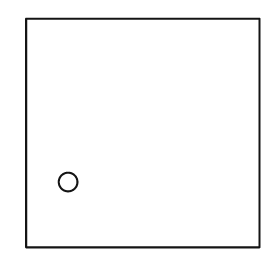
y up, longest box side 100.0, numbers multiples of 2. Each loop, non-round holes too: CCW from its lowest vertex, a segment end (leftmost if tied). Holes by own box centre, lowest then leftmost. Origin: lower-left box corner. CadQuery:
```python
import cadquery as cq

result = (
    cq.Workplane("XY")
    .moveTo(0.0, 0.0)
    .lineTo(100.0, 0.0)
    .lineTo(100.0, 98.0)
    .lineTo(0.0, 98.0)
    .close()
    .moveTo(18.0, 28.0)
    .circle(4.0)
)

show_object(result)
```